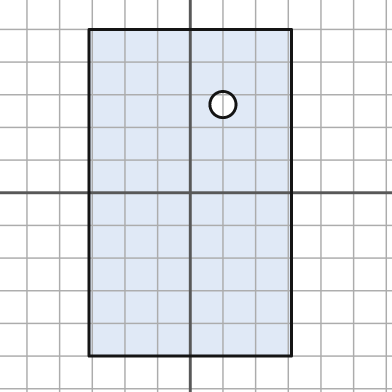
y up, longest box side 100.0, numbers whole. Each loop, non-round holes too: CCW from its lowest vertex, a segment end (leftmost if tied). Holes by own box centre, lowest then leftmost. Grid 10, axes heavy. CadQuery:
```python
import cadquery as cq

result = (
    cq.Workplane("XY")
    .moveTo(-31.0, -50.0)
    .lineTo(31.0, -50.0)
    .lineTo(31.0, 50.0)
    .lineTo(-31.0, 50.0)
    .close()
    .moveTo(10.0, 27.0)
    .circle(4.0)
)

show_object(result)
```